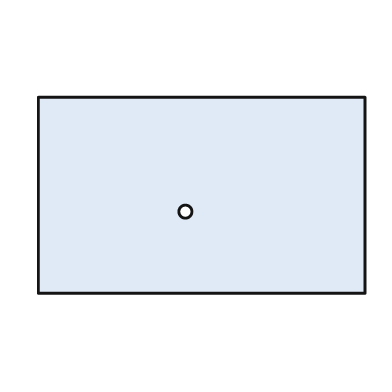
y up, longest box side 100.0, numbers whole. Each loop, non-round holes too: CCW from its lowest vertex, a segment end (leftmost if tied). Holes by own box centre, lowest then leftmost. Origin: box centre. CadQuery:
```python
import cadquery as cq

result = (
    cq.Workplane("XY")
    .moveTo(-50.0, -30.0)
    .lineTo(50.0, -30.0)
    .lineTo(50.0, 30.0)
    .lineTo(-50.0, 30.0)
    .close()
    .moveTo(-5.0, -5.0)
    .circle(2.0)
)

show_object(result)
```